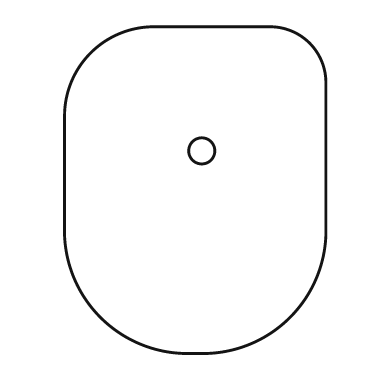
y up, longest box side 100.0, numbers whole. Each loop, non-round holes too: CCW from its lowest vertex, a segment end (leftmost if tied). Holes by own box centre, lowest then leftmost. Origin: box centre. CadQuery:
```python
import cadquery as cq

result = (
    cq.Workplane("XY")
    .moveTo(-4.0, -50.0)
    .lineTo(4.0, -50.0)
    .threePointArc((29.0, -39.0), (40.0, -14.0))
    .lineTo(40.0, 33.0)
    .threePointArc((35.0, 45.0), (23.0, 50.0))
    .lineTo(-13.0, 50.0)
    .threePointArc((-32.0, 42.0), (-40.0, 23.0))
    .lineTo(-40.0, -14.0)
    .threePointArc((-29.0, -39.0), (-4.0, -50.0))
    .close()
    .moveTo(2.0, 12.0)
    .circle(4.0)
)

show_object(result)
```